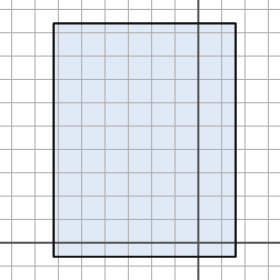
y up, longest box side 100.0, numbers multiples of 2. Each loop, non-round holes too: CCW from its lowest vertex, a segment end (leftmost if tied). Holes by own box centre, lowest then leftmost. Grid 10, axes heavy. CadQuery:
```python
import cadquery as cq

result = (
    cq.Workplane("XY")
    .moveTo(-62.0, -6.0)
    .lineTo(16.0, -6.0)
    .lineTo(16.0, 94.0)
    .lineTo(-62.0, 94.0)
    .close()
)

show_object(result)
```